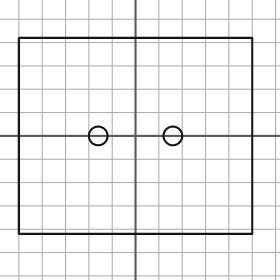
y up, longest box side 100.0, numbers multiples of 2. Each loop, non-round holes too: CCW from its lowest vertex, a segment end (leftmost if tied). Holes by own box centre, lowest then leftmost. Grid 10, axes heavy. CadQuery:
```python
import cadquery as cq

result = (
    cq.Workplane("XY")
    .moveTo(-50.0, -42.0)
    .lineTo(50.0, -42.0)
    .lineTo(50.0, 42.0)
    .lineTo(-50.0, 42.0)
    .close()
    .moveTo(-16.0, 0.0)
    .circle(4.0)
    .moveTo(16.0, 0.0)
    .circle(4.0)
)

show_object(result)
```